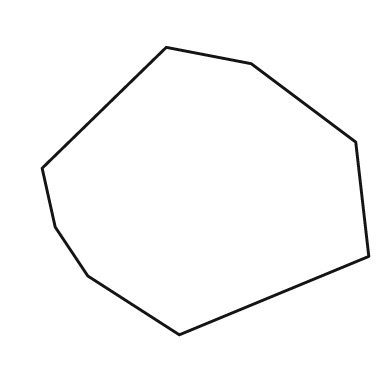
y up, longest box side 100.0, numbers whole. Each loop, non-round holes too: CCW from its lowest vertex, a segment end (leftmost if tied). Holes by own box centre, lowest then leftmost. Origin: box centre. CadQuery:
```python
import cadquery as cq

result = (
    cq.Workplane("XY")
    .moveTo(-8.0, -44.0)
    .lineTo(50.0, -20.0)
    .lineTo(46.0, 15.0)
    .lineTo(14.0, 39.0)
    .lineTo(-12.0, 44.0)
    .lineTo(-50.0, 7.0)
    .lineTo(-46.0, -11.0)
    .lineTo(-36.0, -26.0)
    .close()
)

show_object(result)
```